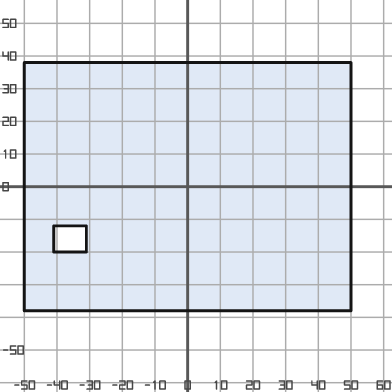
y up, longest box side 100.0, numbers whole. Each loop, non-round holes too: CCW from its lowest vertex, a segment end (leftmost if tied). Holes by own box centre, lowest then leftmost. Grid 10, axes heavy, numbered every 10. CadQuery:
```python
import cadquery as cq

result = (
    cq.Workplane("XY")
    .moveTo(-50.0, -38.0)
    .lineTo(50.0, -38.0)
    .lineTo(50.0, 38.0)
    .lineTo(-50.0, 38.0)
    .close()
    .moveTo(-41.0, -20.0)
    .lineTo(-31.0, -20.0)
    .lineTo(-31.0, -12.0)
    .lineTo(-41.0, -12.0)
    .close()
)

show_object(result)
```